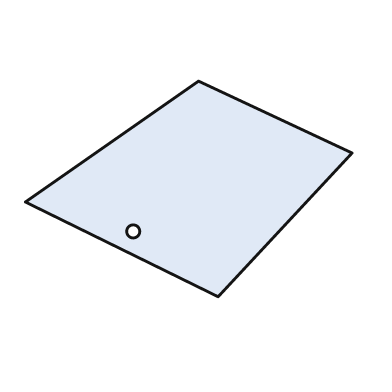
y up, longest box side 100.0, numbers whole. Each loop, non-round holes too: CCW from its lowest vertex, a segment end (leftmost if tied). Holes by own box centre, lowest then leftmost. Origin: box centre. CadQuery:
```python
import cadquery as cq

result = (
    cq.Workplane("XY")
    .moveTo(9.0, -33.0)
    .lineTo(50.0, 11.0)
    .lineTo(3.0, 33.0)
    .lineTo(-50.0, -4.0)
    .close()
    .moveTo(-17.0, -13.0)
    .circle(2.0)
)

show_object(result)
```